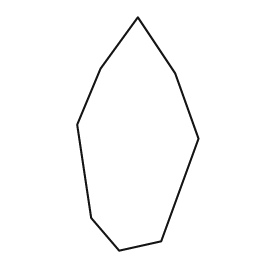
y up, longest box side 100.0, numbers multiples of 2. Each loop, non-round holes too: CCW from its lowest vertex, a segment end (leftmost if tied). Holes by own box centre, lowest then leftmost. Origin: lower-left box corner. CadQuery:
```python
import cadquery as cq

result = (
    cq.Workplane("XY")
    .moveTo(18.0, 0.0)
    .lineTo(36.0, 4.0)
    .lineTo(52.0, 48.0)
    .lineTo(42.0, 76.0)
    .lineTo(26.0, 100.0)
    .lineTo(10.0, 78.0)
    .lineTo(0.0, 54.0)
    .lineTo(6.0, 14.0)
    .close()
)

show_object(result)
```